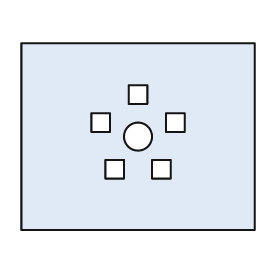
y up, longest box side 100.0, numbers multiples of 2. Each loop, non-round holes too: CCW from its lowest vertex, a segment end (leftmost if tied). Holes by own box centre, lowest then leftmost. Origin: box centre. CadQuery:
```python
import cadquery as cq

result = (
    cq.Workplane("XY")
    .moveTo(-50.0, -40.0)
    .lineTo(50.0, -40.0)
    .lineTo(50.0, 40.0)
    .lineTo(-50.0, 40.0)
    .close()
    .moveTo(-14.0, -18.0)
    .lineTo(-6.0, -18.0)
    .lineTo(-6.0, -10.0)
    .lineTo(-14.0, -10.0)
    .close()
    .moveTo(6.0, -18.0)
    .lineTo(14.0, -18.0)
    .lineTo(14.0, -10.0)
    .lineTo(6.0, -10.0)
    .close()
    .moveTo(0.0, 0.0)
    .circle(6.0)
    .moveTo(-20.0, 2.0)
    .lineTo(-12.0, 2.0)
    .lineTo(-12.0, 10.0)
    .lineTo(-20.0, 10.0)
    .close()
    .moveTo(12.0, 2.0)
    .lineTo(20.0, 2.0)
    .lineTo(20.0, 10.0)
    .lineTo(12.0, 10.0)
    .close()
    .moveTo(-4.0, 14.0)
    .lineTo(4.0, 14.0)
    .lineTo(4.0, 22.0)
    .lineTo(-4.0, 22.0)
    .close()
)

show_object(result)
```